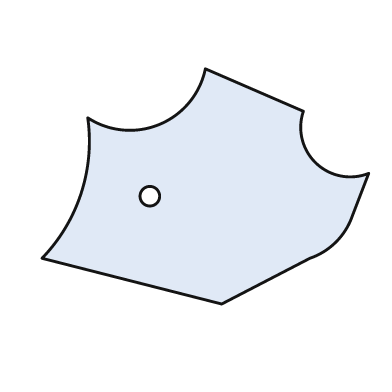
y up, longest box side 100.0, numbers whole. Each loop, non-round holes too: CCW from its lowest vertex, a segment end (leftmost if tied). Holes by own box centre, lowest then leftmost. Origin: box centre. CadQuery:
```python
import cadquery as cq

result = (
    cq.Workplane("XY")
    .moveTo(5.0, -36.0)
    .lineTo(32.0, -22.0)
    .threePointArc((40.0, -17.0), (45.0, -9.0))
    .lineTo(50.0, 4.0)
    .threePointArc((34.0, 7.0), (30.0, 23.0))
    .lineTo(0.0, 36.0)
    .threePointArc((-14.0, 19.0), (-36.0, 21.0))
    .threePointArc((-38.0, -2.0), (-50.0, -22.0))
    .close()
    .moveTo(-17.0, -3.0)
    .circle(3.0)
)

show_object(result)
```